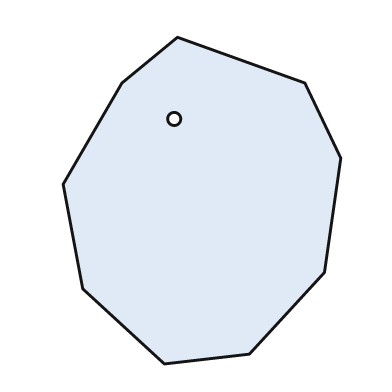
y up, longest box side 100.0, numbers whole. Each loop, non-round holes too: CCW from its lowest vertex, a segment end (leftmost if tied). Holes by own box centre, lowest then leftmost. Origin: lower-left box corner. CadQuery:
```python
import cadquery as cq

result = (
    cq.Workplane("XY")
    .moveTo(31.0, 0.0)
    .lineTo(57.0, 3.0)
    .lineTo(80.0, 28.0)
    .lineTo(85.0, 63.0)
    .lineTo(74.0, 86.0)
    .lineTo(35.0, 100.0)
    .lineTo(18.0, 86.0)
    .lineTo(0.0, 55.0)
    .lineTo(6.0, 23.0)
    .close()
    .moveTo(34.0, 75.0)
    .circle(2.0)
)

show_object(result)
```